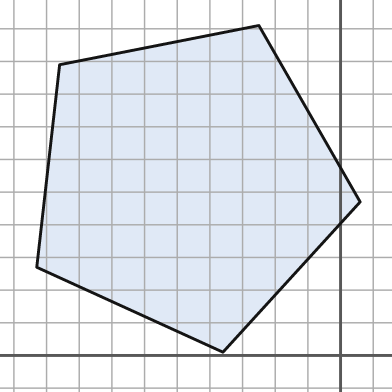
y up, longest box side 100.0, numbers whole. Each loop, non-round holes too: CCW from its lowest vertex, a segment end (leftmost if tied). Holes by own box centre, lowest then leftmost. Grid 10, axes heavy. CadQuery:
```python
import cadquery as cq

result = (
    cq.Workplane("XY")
    .moveTo(-36.0, 1.0)
    .lineTo(6.0, 47.0)
    .lineTo(-25.0, 101.0)
    .lineTo(-86.0, 89.0)
    .lineTo(-93.0, 27.0)
    .close()
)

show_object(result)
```